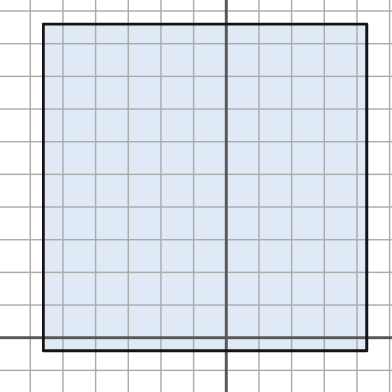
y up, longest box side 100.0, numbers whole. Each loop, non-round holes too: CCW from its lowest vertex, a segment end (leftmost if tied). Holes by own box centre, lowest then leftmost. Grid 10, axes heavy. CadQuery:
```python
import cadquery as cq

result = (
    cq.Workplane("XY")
    .moveTo(-56.0, -4.0)
    .lineTo(43.0, -4.0)
    .lineTo(43.0, 96.0)
    .lineTo(-56.0, 96.0)
    .close()
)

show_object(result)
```